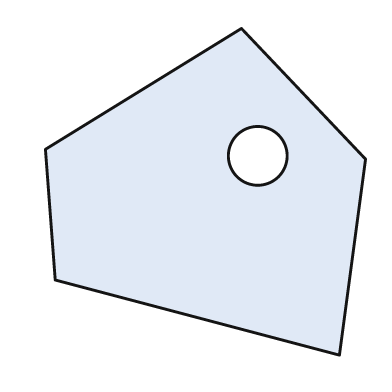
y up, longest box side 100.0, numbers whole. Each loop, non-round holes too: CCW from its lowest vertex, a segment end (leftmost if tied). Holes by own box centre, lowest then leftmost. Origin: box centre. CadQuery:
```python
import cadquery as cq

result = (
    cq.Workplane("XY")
    .moveTo(41.0, -50.0)
    .lineTo(49.0, 10.0)
    .lineTo(11.0, 50.0)
    .lineTo(-49.0, 13.0)
    .lineTo(-46.0, -27.0)
    .close()
    .moveTo(16.0, 11.0)
    .circle(9.0)
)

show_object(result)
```